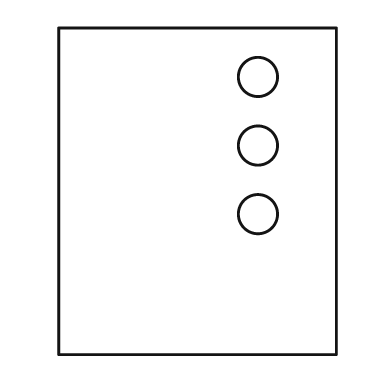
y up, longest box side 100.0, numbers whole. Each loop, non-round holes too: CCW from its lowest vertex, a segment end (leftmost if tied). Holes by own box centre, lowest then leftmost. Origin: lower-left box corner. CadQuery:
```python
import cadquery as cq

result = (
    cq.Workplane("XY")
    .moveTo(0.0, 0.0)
    .lineTo(85.0, 0.0)
    .lineTo(85.0, 100.0)
    .lineTo(0.0, 100.0)
    .close()
    .moveTo(61.0, 43.0)
    .circle(6.0)
    .moveTo(61.0, 64.0)
    .circle(6.0)
    .moveTo(61.0, 85.0)
    .circle(6.0)
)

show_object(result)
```